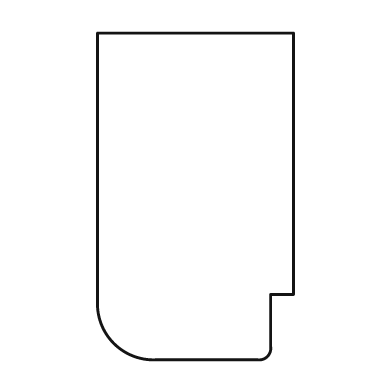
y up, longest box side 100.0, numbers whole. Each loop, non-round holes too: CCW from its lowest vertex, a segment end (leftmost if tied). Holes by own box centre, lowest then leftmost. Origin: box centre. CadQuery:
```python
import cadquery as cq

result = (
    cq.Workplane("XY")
    .moveTo(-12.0, -50.0)
    .lineTo(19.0, -50.0)
    .threePointArc((22.0, -49.0), (23.0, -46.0))
    .lineTo(23.0, -30.0)
    .lineTo(30.0, -30.0)
    .lineTo(30.0, 50.0)
    .lineTo(-30.0, 50.0)
    .lineTo(-30.0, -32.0)
    .threePointArc((-25.0, -45.0), (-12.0, -50.0))
    .close()
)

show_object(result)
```